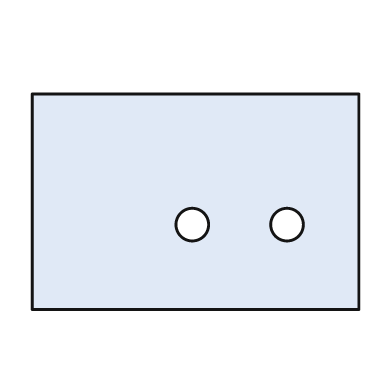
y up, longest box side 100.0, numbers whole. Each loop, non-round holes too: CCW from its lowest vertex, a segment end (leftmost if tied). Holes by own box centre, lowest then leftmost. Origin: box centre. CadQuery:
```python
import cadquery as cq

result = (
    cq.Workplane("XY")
    .moveTo(-50.0, -33.0)
    .lineTo(50.0, -33.0)
    .lineTo(50.0, 33.0)
    .lineTo(-50.0, 33.0)
    .close()
    .moveTo(-1.0, -7.0)
    .circle(5.0)
    .moveTo(28.0, -7.0)
    .circle(5.0)
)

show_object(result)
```